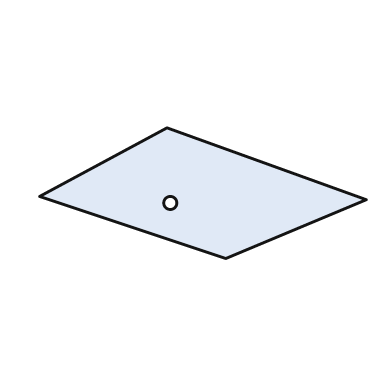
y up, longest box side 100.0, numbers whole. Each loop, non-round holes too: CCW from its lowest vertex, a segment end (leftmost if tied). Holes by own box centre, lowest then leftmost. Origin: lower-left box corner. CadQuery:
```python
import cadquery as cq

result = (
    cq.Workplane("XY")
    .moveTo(57.0, 0.0)
    .lineTo(100.0, 18.0)
    .lineTo(39.0, 40.0)
    .lineTo(0.0, 19.0)
    .close()
    .moveTo(40.0, 17.0)
    .circle(2.0)
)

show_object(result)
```